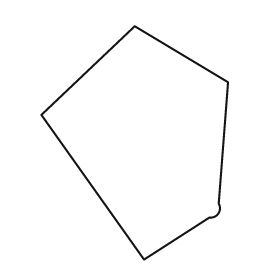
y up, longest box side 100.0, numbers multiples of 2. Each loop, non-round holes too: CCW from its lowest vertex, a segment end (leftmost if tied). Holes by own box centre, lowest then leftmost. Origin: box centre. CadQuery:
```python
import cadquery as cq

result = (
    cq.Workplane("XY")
    .moveTo(4.0, -50.0)
    .lineTo(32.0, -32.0)
    .threePointArc((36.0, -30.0), (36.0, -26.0))
    .lineTo(40.0, 26.0)
    .lineTo(0.0, 50.0)
    .lineTo(-40.0, 12.0)
    .close()
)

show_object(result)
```